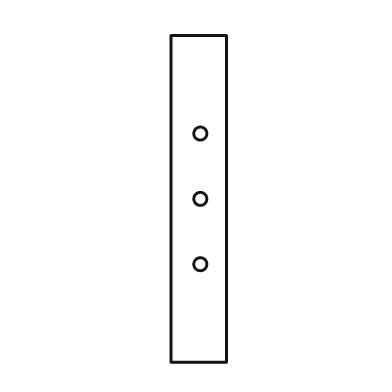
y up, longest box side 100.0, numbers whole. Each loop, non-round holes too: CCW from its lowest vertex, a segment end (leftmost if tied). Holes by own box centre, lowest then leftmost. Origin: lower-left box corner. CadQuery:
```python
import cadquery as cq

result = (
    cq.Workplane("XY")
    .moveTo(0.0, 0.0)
    .lineTo(17.0, 0.0)
    .lineTo(17.0, 100.0)
    .lineTo(0.0, 100.0)
    .close()
    .moveTo(9.0, 30.0)
    .circle(2.0)
    .moveTo(9.0, 50.0)
    .circle(2.0)
    .moveTo(9.0, 70.0)
    .circle(2.0)
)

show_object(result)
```